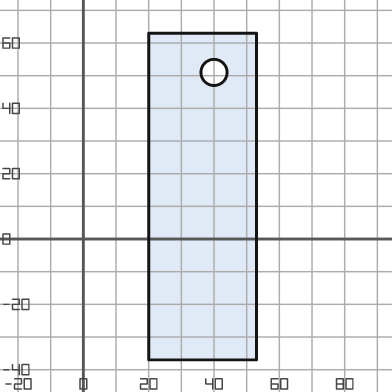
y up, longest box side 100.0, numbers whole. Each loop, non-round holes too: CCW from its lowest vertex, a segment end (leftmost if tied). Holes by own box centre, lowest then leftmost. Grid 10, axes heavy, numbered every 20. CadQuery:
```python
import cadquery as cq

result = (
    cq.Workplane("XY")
    .moveTo(20.0, -37.0)
    .lineTo(53.0, -37.0)
    .lineTo(53.0, 63.0)
    .lineTo(20.0, 63.0)
    .close()
    .moveTo(40.0, 51.0)
    .circle(4.0)
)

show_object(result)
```